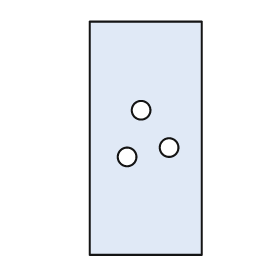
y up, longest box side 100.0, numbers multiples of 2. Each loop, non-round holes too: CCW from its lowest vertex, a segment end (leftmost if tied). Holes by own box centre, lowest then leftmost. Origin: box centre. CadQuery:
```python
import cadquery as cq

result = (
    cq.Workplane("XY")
    .moveTo(-24.0, -50.0)
    .lineTo(24.0, -50.0)
    .lineTo(24.0, 50.0)
    .lineTo(-24.0, 50.0)
    .close()
    .moveTo(-8.0, -8.0)
    .circle(4.0)
    .moveTo(10.0, -4.0)
    .circle(4.0)
    .moveTo(-2.0, 12.0)
    .circle(4.0)
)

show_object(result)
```